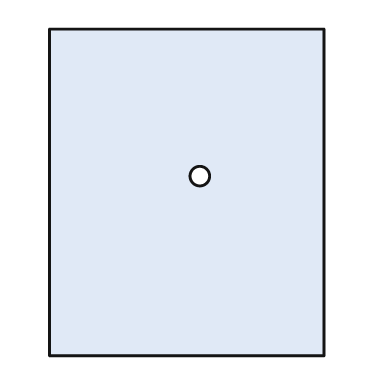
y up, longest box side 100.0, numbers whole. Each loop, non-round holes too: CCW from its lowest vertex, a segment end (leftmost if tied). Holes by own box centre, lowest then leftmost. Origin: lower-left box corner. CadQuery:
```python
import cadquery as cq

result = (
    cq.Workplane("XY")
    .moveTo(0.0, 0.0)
    .lineTo(84.0, 0.0)
    .lineTo(84.0, 100.0)
    .lineTo(0.0, 100.0)
    .close()
    .moveTo(46.0, 55.0)
    .circle(3.0)
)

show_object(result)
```